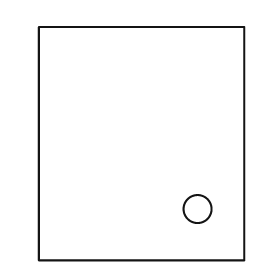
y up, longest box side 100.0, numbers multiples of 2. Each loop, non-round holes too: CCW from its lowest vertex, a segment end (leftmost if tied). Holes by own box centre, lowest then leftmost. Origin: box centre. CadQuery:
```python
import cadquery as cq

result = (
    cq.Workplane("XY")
    .moveTo(-44.0, -50.0)
    .lineTo(44.0, -50.0)
    .lineTo(44.0, 50.0)
    .lineTo(-44.0, 50.0)
    .close()
    .moveTo(24.0, -28.0)
    .circle(6.0)
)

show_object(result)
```